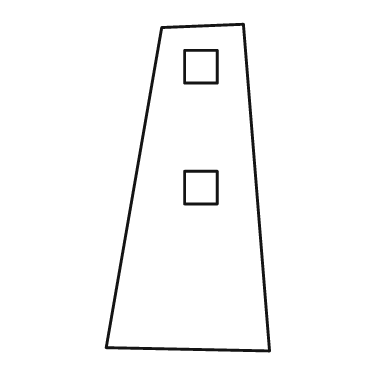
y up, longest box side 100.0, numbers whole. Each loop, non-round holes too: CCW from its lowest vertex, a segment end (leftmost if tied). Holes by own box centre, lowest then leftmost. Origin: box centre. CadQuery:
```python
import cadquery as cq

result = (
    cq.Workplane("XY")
    .moveTo(25.0, -50.0)
    .lineTo(17.0, 50.0)
    .lineTo(-8.0, 49.0)
    .lineTo(-25.0, -49.0)
    .close()
    .moveTo(-1.0, -5.0)
    .lineTo(9.0, -5.0)
    .lineTo(9.0, 5.0)
    .lineTo(-1.0, 5.0)
    .close()
    .moveTo(-1.0, 32.0)
    .lineTo(9.0, 32.0)
    .lineTo(9.0, 42.0)
    .lineTo(-1.0, 42.0)
    .close()
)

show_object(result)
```